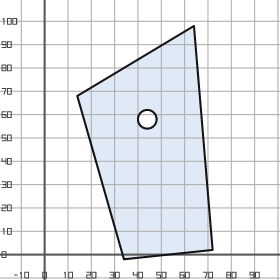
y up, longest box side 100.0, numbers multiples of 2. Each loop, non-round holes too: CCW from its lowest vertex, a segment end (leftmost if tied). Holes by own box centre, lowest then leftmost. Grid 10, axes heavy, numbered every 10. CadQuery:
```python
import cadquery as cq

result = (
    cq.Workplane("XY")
    .moveTo(34.0, -2.0)
    .lineTo(72.0, 2.0)
    .lineTo(64.0, 98.0)
    .lineTo(14.0, 68.0)
    .close()
    .moveTo(44.0, 58.0)
    .circle(4.0)
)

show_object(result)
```